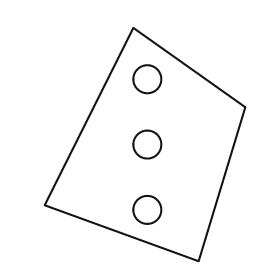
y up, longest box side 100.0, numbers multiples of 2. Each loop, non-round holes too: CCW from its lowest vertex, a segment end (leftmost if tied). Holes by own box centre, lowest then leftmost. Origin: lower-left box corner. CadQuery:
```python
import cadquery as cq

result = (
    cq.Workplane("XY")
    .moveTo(66.0, 0.0)
    .lineTo(86.0, 66.0)
    .lineTo(38.0, 100.0)
    .lineTo(0.0, 24.0)
    .close()
    .moveTo(44.0, 22.0)
    .circle(6.0)
    .moveTo(44.0, 50.0)
    .circle(6.0)
    .moveTo(44.0, 78.0)
    .circle(6.0)
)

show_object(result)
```